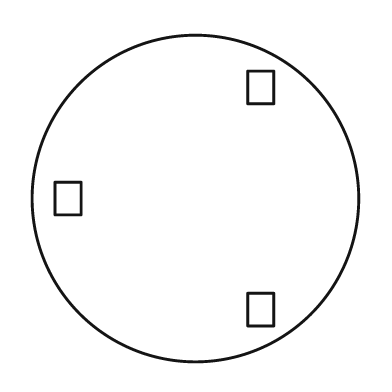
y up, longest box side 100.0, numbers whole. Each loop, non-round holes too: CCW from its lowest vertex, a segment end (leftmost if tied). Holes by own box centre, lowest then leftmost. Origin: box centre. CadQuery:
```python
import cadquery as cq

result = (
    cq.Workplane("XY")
    .moveTo(0.0, 0.0)
    .circle(50.0)
    .moveTo(16.0, -39.0)
    .lineTo(24.0, -39.0)
    .lineTo(24.0, -29.0)
    .lineTo(16.0, -29.0)
    .close()
    .moveTo(-43.0, -5.0)
    .lineTo(-35.0, -5.0)
    .lineTo(-35.0, 5.0)
    .lineTo(-43.0, 5.0)
    .close()
    .moveTo(16.0, 29.0)
    .lineTo(24.0, 29.0)
    .lineTo(24.0, 39.0)
    .lineTo(16.0, 39.0)
    .close()
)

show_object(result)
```